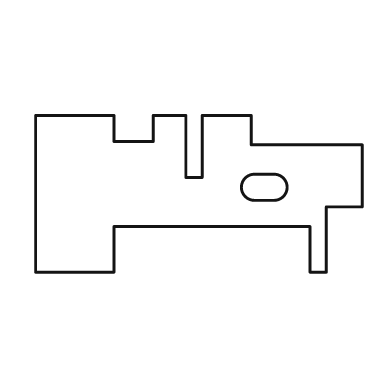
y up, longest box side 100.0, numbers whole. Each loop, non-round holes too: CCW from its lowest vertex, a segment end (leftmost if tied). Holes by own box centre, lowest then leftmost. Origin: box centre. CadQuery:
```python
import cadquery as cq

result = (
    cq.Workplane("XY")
    .moveTo(-50.0, -24.0)
    .lineTo(-26.0, -24.0)
    .lineTo(-26.0, -10.0)
    .lineTo(34.0, -10.0)
    .lineTo(34.0, -24.0)
    .lineTo(39.0, -24.0)
    .lineTo(39.0, -4.0)
    .lineTo(50.0, -4.0)
    .lineTo(50.0, 15.0)
    .lineTo(16.0, 15.0)
    .lineTo(16.0, 24.0)
    .lineTo(1.0, 24.0)
    .lineTo(1.0, 5.0)
    .lineTo(-4.0, 5.0)
    .lineTo(-4.0, 24.0)
    .lineTo(-14.0, 24.0)
    .lineTo(-14.0, 16.0)
    .lineTo(-26.0, 16.0)
    .lineTo(-26.0, 24.0)
    .lineTo(-50.0, 24.0)
    .close()
    .moveTo(17.0, -2.0)
    .lineTo(23.0, -2.0)
    .threePointArc((27.0, 2.0), (23.0, 6.0))
    .lineTo(17.0, 6.0)
    .threePointArc((13.0, 2.0), (17.0, -2.0))
    .close()
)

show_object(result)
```